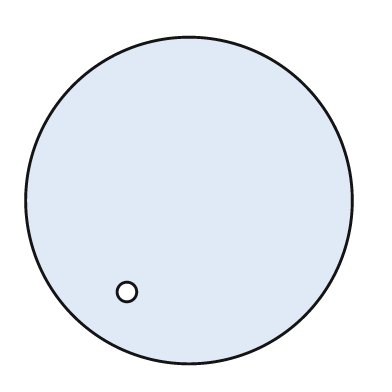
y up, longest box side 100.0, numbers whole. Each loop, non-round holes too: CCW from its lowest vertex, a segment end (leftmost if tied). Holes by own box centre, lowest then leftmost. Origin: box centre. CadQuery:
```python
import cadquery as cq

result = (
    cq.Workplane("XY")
    .moveTo(0.0, 0.0)
    .circle(50.0)
    .moveTo(-19.0, -28.0)
    .circle(3.0)
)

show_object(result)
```